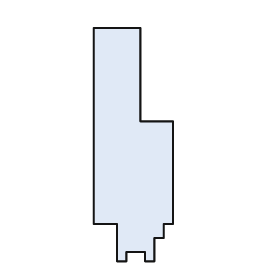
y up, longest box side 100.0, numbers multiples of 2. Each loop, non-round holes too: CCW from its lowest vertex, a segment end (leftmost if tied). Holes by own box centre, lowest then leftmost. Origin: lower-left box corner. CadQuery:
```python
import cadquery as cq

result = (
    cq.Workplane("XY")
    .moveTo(10.0, 0.0)
    .lineTo(14.0, 0.0)
    .lineTo(14.0, 4.0)
    .lineTo(22.0, 4.0)
    .lineTo(22.0, 0.0)
    .lineTo(26.0, 0.0)
    .lineTo(26.0, 10.0)
    .lineTo(30.0, 10.0)
    .lineTo(30.0, 16.0)
    .lineTo(34.0, 16.0)
    .lineTo(34.0, 60.0)
    .lineTo(20.0, 60.0)
    .lineTo(20.0, 100.0)
    .lineTo(0.0, 100.0)
    .lineTo(0.0, 16.0)
    .lineTo(10.0, 16.0)
    .close()
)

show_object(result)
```